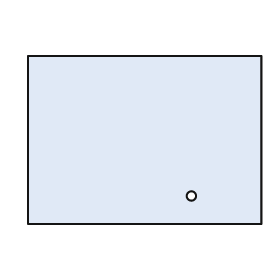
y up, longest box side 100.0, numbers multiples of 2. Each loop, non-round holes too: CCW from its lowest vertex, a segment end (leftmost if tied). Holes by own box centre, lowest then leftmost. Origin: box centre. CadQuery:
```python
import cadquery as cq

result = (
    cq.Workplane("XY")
    .moveTo(-50.0, -36.0)
    .lineTo(50.0, -36.0)
    .lineTo(50.0, 36.0)
    .lineTo(-50.0, 36.0)
    .close()
    .moveTo(20.0, -24.0)
    .circle(2.0)
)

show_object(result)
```